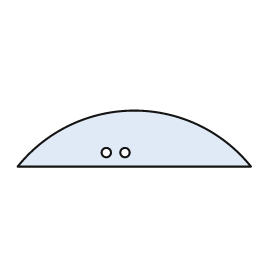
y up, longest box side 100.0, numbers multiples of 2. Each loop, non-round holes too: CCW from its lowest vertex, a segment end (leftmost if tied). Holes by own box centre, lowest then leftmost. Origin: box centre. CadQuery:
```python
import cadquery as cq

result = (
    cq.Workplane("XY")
    .moveTo(-50.0, -12.0)
    .lineTo(50.0, -12.0)
    .threePointArc((0.0, 12.0), (-50.0, -12.0))
    .close()
    .moveTo(-12.0, -6.0)
    .circle(2.0)
    .moveTo(-4.0, -6.0)
    .circle(2.0)
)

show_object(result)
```